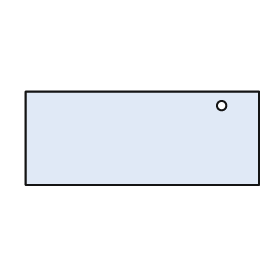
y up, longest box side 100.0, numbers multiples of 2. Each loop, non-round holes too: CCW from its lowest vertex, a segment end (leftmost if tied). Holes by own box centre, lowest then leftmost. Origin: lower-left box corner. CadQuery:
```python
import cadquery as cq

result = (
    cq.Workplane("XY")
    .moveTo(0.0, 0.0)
    .lineTo(100.0, 0.0)
    .lineTo(100.0, 40.0)
    .lineTo(0.0, 40.0)
    .close()
    .moveTo(84.0, 34.0)
    .circle(2.0)
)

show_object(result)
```